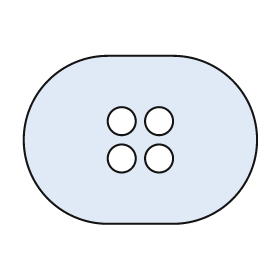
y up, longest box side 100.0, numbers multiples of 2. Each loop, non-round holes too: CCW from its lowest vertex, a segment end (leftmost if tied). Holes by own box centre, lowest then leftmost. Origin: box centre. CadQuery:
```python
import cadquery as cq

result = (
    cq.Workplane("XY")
    .moveTo(-14.0, -36.0)
    .lineTo(14.0, -36.0)
    .threePointArc((50.0, 0.0), (14.0, 36.0))
    .lineTo(-14.0, 36.0)
    .threePointArc((-50.0, 0.0), (-14.0, -36.0))
    .close()
    .moveTo(-8.0, -8.0)
    .circle(6.0)
    .moveTo(8.0, -8.0)
    .circle(6.0)
    .moveTo(-8.0, 8.0)
    .circle(6.0)
    .moveTo(8.0, 8.0)
    .circle(6.0)
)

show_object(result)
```